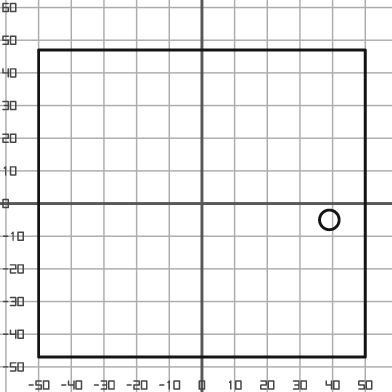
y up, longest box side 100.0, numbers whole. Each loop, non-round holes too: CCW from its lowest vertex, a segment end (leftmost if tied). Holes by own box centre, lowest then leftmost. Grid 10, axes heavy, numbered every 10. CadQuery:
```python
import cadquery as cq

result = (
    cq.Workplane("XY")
    .moveTo(-50.0, -47.0)
    .lineTo(50.0, -47.0)
    .lineTo(50.0, 47.0)
    .lineTo(-50.0, 47.0)
    .close()
    .moveTo(39.0, -5.0)
    .circle(3.0)
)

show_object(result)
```